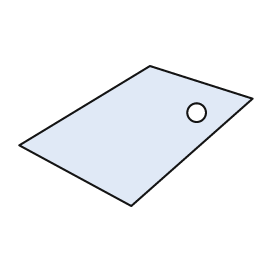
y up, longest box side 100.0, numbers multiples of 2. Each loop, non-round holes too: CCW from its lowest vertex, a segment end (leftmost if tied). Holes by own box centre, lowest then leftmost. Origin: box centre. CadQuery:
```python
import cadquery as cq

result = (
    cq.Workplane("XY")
    .moveTo(-2.0, -30.0)
    .lineTo(50.0, 16.0)
    .lineTo(6.0, 30.0)
    .lineTo(-50.0, -4.0)
    .close()
    .moveTo(26.0, 10.0)
    .circle(4.0)
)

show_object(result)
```